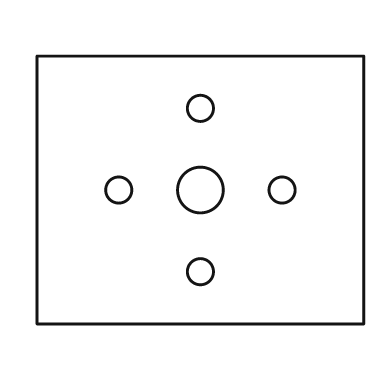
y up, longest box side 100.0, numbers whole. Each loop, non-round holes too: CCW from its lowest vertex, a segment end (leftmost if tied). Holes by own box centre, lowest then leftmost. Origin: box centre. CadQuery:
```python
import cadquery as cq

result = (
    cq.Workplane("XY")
    .moveTo(-50.0, -41.0)
    .lineTo(50.0, -41.0)
    .lineTo(50.0, 41.0)
    .lineTo(-50.0, 41.0)
    .close()
    .moveTo(0.0, -25.0)
    .circle(4.0)
    .moveTo(-25.0, 0.0)
    .circle(4.0)
    .moveTo(0.0, 0.0)
    .circle(7.0)
    .moveTo(25.0, 0.0)
    .circle(4.0)
    .moveTo(0.0, 25.0)
    .circle(4.0)
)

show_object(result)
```